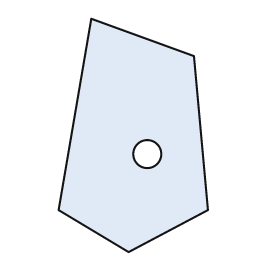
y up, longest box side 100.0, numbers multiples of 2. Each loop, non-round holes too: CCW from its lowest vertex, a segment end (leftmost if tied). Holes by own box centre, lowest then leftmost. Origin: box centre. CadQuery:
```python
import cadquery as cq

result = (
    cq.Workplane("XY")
    .moveTo(-2.0, -50.0)
    .lineTo(32.0, -32.0)
    .lineTo(26.0, 34.0)
    .lineTo(-18.0, 50.0)
    .lineTo(-32.0, -32.0)
    .close()
    .moveTo(6.0, -8.0)
    .circle(6.0)
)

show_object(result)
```